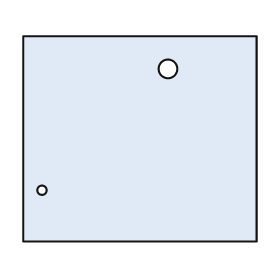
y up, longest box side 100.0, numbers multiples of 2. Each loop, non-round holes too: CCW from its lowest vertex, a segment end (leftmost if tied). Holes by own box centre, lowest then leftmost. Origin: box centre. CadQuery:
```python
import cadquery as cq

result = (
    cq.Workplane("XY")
    .moveTo(-50.0, -44.0)
    .lineTo(50.0, -44.0)
    .lineTo(50.0, 44.0)
    .lineTo(-50.0, 44.0)
    .close()
    .moveTo(-42.0, -22.0)
    .circle(2.0)
    .moveTo(12.0, 30.0)
    .circle(4.0)
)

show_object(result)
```